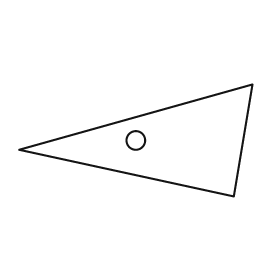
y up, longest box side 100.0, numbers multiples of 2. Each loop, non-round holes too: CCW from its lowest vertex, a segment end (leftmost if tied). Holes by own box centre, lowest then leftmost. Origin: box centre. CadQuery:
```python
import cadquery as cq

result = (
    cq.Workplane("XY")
    .moveTo(42.0, -24.0)
    .lineTo(50.0, 24.0)
    .lineTo(-50.0, -4.0)
    .close()
    .moveTo(0.0, 0.0)
    .circle(4.0)
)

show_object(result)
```